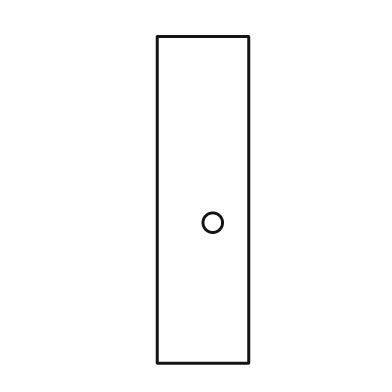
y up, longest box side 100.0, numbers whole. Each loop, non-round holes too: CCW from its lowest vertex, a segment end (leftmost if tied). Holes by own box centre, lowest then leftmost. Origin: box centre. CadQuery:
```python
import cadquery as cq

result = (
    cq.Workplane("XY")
    .moveTo(-14.0, -50.0)
    .lineTo(14.0, -50.0)
    .lineTo(14.0, 50.0)
    .lineTo(-14.0, 50.0)
    .close()
    .moveTo(3.0, -7.0)
    .circle(3.0)
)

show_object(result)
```